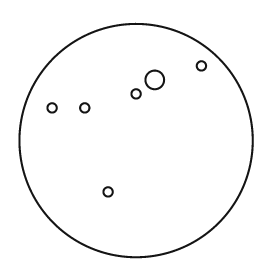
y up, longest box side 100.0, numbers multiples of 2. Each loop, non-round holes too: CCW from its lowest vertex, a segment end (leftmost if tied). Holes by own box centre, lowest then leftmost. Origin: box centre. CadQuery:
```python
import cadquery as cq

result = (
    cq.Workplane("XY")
    .moveTo(0.0, 0.0)
    .circle(50.0)
    .moveTo(-12.0, -22.0)
    .circle(2.0)
    .moveTo(-36.0, 14.0)
    .circle(2.0)
    .moveTo(-22.0, 14.0)
    .circle(2.0)
    .moveTo(0.0, 20.0)
    .circle(2.0)
    .moveTo(8.0, 26.0)
    .circle(4.0)
    .moveTo(28.0, 32.0)
    .circle(2.0)
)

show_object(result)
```